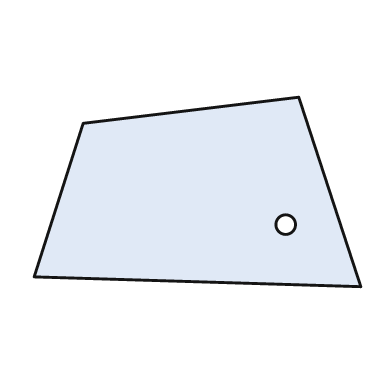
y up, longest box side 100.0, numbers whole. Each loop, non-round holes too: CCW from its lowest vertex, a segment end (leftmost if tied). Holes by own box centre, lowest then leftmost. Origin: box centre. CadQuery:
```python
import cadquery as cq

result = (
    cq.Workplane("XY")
    .moveTo(50.0, -29.0)
    .lineTo(31.0, 29.0)
    .lineTo(-35.0, 21.0)
    .lineTo(-50.0, -26.0)
    .close()
    .moveTo(27.0, -10.0)
    .circle(3.0)
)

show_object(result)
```